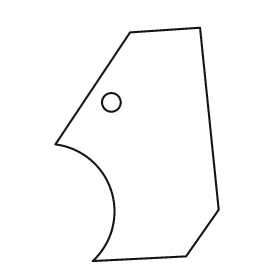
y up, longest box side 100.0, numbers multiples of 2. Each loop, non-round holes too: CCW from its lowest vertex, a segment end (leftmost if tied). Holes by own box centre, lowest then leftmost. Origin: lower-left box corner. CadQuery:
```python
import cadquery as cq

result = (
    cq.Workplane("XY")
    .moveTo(16.0, 0.0)
    .lineTo(56.0, 2.0)
    .lineTo(70.0, 22.0)
    .lineTo(62.0, 100.0)
    .lineTo(32.0, 98.0)
    .lineTo(0.0, 50.0)
    .threePointArc((24.0, 30.0), (16.0, 0.0))
    .close()
    .moveTo(24.0, 68.0)
    .circle(4.0)
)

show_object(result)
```